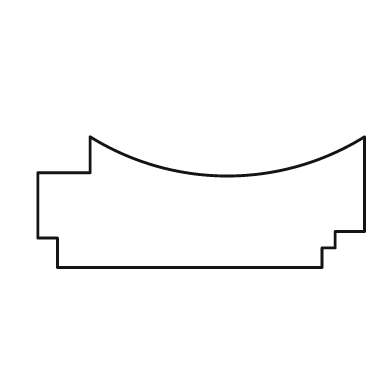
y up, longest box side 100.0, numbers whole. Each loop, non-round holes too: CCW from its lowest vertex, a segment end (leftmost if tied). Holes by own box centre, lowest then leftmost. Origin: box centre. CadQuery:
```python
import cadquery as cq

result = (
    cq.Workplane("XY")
    .moveTo(-44.0, -20.0)
    .lineTo(37.0, -20.0)
    .lineTo(37.0, -14.0)
    .lineTo(41.0, -14.0)
    .lineTo(41.0, -9.0)
    .lineTo(50.0, -9.0)
    .lineTo(50.0, 20.0)
    .threePointArc((8.0, 8.0), (-34.0, 20.0))
    .lineTo(-34.0, 9.0)
    .lineTo(-50.0, 9.0)
    .lineTo(-50.0, -11.0)
    .lineTo(-44.0, -11.0)
    .close()
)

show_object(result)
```